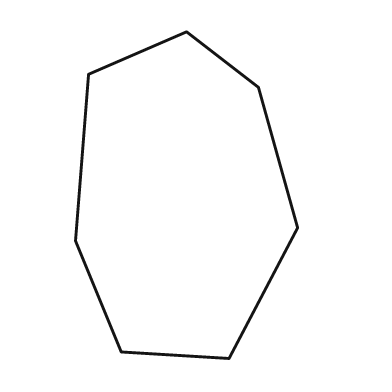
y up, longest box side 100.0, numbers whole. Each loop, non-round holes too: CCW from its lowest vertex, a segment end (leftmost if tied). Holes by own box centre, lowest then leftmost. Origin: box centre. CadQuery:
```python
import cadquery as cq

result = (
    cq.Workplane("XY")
    .moveTo(13.0, -50.0)
    .lineTo(34.0, -10.0)
    .lineTo(22.0, 33.0)
    .lineTo(0.0, 50.0)
    .lineTo(-30.0, 37.0)
    .lineTo(-34.0, -14.0)
    .lineTo(-20.0, -48.0)
    .close()
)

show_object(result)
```